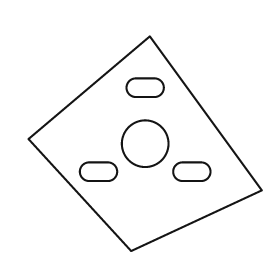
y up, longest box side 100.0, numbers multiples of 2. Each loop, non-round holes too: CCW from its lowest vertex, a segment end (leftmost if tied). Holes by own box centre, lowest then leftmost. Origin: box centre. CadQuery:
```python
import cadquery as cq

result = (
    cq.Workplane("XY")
    .moveTo(-6.0, -46.0)
    .lineTo(50.0, -20.0)
    .lineTo(2.0, 46.0)
    .lineTo(-50.0, 2.0)
    .close()
    .moveTo(-24.0, -16.0)
    .lineTo(-16.0, -16.0)
    .threePointArc((-12.0, -12.0), (-16.0, -8.0))
    .lineTo(-24.0, -8.0)
    .threePointArc((-28.0, -12.0), (-24.0, -16.0))
    .close()
    .moveTo(16.0, -16.0)
    .lineTo(24.0, -16.0)
    .threePointArc((28.0, -12.0), (24.0, -8.0))
    .lineTo(16.0, -8.0)
    .threePointArc((12.0, -12.0), (16.0, -16.0))
    .close()
    .moveTo(0.0, 0.0)
    .circle(10.0)
    .moveTo(-4.0, 20.0)
    .lineTo(4.0, 20.0)
    .threePointArc((8.0, 24.0), (4.0, 28.0))
    .lineTo(-4.0, 28.0)
    .threePointArc((-8.0, 24.0), (-4.0, 20.0))
    .close()
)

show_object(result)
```